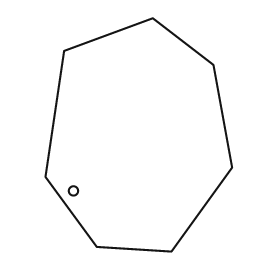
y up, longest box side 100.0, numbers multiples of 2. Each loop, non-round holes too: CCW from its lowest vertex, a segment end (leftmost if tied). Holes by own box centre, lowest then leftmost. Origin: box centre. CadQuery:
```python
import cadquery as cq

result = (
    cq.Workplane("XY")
    .moveTo(14.0, -50.0)
    .lineTo(40.0, -14.0)
    .lineTo(32.0, 30.0)
    .lineTo(6.0, 50.0)
    .lineTo(-32.0, 36.0)
    .lineTo(-40.0, -18.0)
    .lineTo(-18.0, -48.0)
    .close()
    .moveTo(-28.0, -24.0)
    .circle(2.0)
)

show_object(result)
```